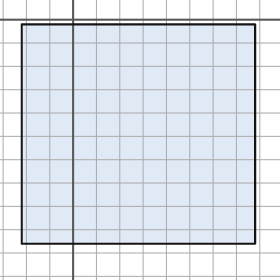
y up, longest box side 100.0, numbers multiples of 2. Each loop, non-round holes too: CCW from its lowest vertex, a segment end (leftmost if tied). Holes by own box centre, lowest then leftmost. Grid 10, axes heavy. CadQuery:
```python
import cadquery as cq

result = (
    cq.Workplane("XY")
    .moveTo(-22.0, -96.0)
    .lineTo(78.0, -96.0)
    .lineTo(78.0, -2.0)
    .lineTo(-22.0, -2.0)
    .close()
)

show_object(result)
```